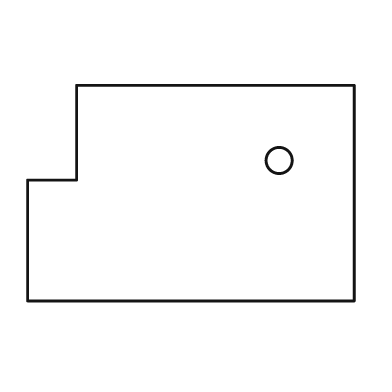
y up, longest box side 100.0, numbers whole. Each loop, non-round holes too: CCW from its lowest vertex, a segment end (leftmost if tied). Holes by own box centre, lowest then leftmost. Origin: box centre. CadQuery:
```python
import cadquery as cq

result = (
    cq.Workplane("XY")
    .moveTo(-50.0, -33.0)
    .lineTo(50.0, -33.0)
    .lineTo(50.0, 33.0)
    .lineTo(-35.0, 33.0)
    .lineTo(-35.0, 4.0)
    .lineTo(-50.0, 4.0)
    .close()
    .moveTo(27.0, 10.0)
    .circle(4.0)
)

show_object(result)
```